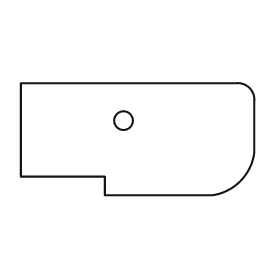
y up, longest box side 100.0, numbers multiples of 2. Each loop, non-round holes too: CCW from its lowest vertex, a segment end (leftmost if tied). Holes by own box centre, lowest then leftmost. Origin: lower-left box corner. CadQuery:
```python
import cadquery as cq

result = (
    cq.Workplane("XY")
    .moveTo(36.0, 0.0)
    .lineTo(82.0, 0.0)
    .threePointArc((94.0, 6.0), (100.0, 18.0))
    .lineTo(100.0, 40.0)
    .threePointArc((98.0, 46.0), (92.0, 48.0))
    .lineTo(0.0, 48.0)
    .lineTo(0.0, 8.0)
    .lineTo(36.0, 8.0)
    .close()
    .moveTo(44.0, 32.0)
    .circle(4.0)
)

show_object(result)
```